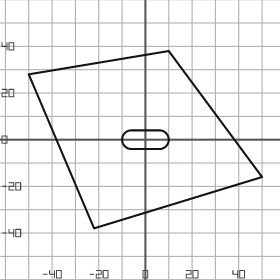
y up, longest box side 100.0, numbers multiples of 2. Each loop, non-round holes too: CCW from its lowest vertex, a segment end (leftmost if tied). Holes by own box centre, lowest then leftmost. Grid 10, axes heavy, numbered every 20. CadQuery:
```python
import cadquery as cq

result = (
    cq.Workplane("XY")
    .moveTo(-22.0, -38.0)
    .lineTo(50.0, -16.0)
    .lineTo(10.0, 38.0)
    .lineTo(-50.0, 28.0)
    .close()
    .moveTo(-6.0, -4.0)
    .lineTo(6.0, -4.0)
    .threePointArc((10.0, 0.0), (6.0, 4.0))
    .lineTo(-6.0, 4.0)
    .threePointArc((-10.0, 0.0), (-6.0, -4.0))
    .close()
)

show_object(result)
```